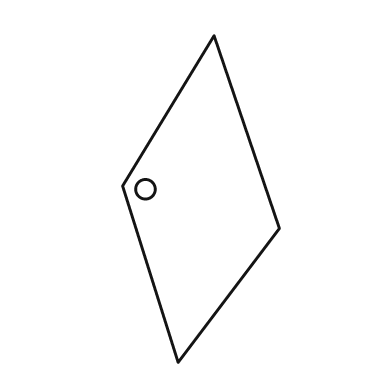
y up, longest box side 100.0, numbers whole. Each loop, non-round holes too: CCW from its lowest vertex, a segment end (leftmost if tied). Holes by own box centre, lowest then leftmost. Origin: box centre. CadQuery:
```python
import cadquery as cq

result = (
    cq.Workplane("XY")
    .moveTo(-7.0, -50.0)
    .lineTo(24.0, -9.0)
    .lineTo(4.0, 50.0)
    .lineTo(-24.0, 4.0)
    .close()
    .moveTo(-17.0, 3.0)
    .circle(3.0)
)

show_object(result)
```